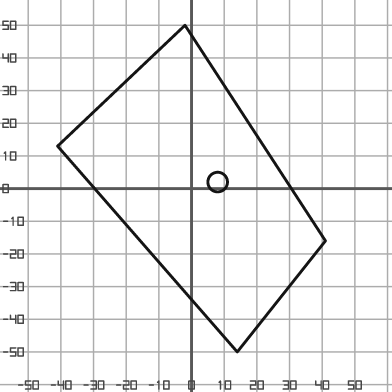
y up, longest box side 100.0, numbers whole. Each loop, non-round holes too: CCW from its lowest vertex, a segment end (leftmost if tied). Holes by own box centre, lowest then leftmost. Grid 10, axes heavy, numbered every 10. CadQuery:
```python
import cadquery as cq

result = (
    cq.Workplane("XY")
    .moveTo(14.0, -50.0)
    .lineTo(41.0, -16.0)
    .lineTo(-2.0, 50.0)
    .lineTo(-41.0, 13.0)
    .close()
    .moveTo(8.0, 2.0)
    .circle(3.0)
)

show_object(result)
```